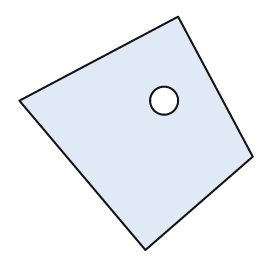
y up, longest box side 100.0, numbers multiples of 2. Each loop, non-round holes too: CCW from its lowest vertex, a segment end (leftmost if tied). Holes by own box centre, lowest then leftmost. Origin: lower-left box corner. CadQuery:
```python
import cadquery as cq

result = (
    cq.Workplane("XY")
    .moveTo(54.0, 0.0)
    .lineTo(100.0, 40.0)
    .lineTo(68.0, 100.0)
    .lineTo(0.0, 64.0)
    .close()
    .moveTo(62.0, 64.0)
    .circle(6.0)
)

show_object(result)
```